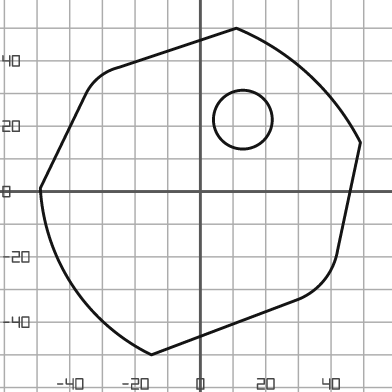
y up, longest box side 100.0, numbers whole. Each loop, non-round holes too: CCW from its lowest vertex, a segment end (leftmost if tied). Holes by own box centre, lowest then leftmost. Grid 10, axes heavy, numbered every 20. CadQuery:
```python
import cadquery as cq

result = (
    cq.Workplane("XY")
    .moveTo(-15.0, -50.0)
    .lineTo(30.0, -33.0)
    .threePointArc((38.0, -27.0), (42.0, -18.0))
    .lineTo(49.0, 15.0)
    .threePointArc((33.0, 36.0), (11.0, 50.0))
    .lineTo(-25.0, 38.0)
    .threePointArc((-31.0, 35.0), (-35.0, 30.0))
    .lineTo(-49.0, 1.0)
    .threePointArc((-39.0, -29.0), (-15.0, -50.0))
    .close()
    .moveTo(13.0, 22.0)
    .circle(9.0)
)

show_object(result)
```